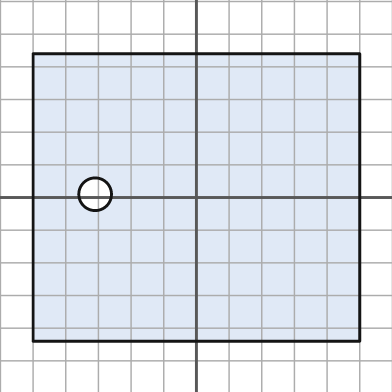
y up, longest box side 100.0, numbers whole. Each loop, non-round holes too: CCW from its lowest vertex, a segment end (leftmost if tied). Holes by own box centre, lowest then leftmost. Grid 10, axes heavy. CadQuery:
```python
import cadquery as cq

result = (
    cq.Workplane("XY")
    .moveTo(-50.0, -44.0)
    .lineTo(50.0, -44.0)
    .lineTo(50.0, 44.0)
    .lineTo(-50.0, 44.0)
    .close()
    .moveTo(-31.0, 1.0)
    .circle(5.0)
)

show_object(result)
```